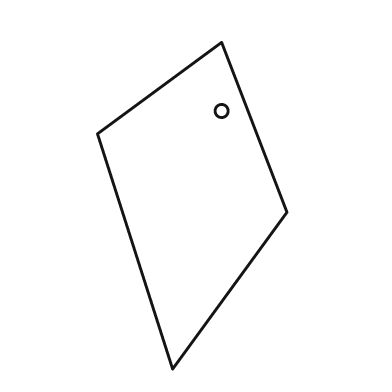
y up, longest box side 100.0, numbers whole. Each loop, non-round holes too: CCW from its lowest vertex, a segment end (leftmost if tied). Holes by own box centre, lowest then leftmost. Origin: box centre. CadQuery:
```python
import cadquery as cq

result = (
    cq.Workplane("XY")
    .moveTo(-6.0, -50.0)
    .lineTo(29.0, -2.0)
    .lineTo(9.0, 50.0)
    .lineTo(-29.0, 22.0)
    .close()
    .moveTo(9.0, 29.0)
    .circle(2.0)
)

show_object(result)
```